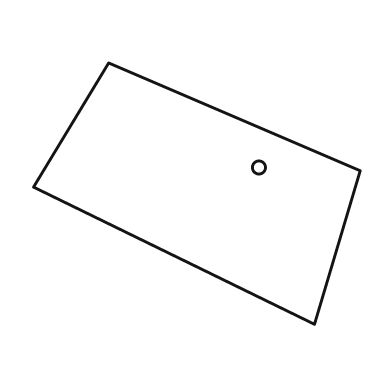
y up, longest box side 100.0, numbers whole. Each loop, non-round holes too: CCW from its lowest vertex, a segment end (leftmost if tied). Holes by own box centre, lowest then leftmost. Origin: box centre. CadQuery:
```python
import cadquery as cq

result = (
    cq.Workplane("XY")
    .moveTo(36.0, -40.0)
    .lineTo(50.0, 7.0)
    .lineTo(-27.0, 40.0)
    .lineTo(-50.0, 2.0)
    .close()
    .moveTo(19.0, 8.0)
    .circle(2.0)
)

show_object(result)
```